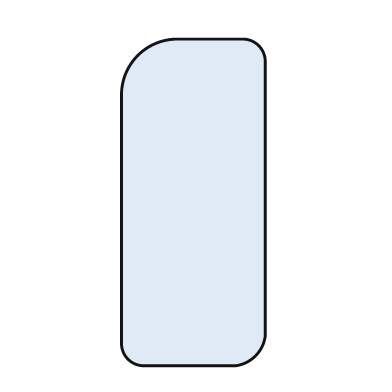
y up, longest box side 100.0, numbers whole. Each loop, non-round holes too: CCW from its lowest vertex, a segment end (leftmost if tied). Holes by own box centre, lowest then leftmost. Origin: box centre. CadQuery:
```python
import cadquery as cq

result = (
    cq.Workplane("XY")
    .moveTo(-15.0, -50.0)
    .lineTo(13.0, -50.0)
    .threePointArc((19.0, -47.0), (22.0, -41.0))
    .lineTo(22.0, 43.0)
    .threePointArc((20.0, 48.0), (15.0, 50.0))
    .lineTo(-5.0, 50.0)
    .threePointArc((-17.0, 45.0), (-22.0, 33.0))
    .lineTo(-22.0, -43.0)
    .threePointArc((-20.0, -48.0), (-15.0, -50.0))
    .close()
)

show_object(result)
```